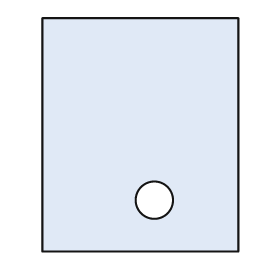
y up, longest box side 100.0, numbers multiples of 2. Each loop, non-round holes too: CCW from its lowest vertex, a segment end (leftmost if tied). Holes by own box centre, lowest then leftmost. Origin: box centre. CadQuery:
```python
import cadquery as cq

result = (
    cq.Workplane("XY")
    .moveTo(-42.0, -50.0)
    .lineTo(42.0, -50.0)
    .lineTo(42.0, 50.0)
    .lineTo(-42.0, 50.0)
    .close()
    .moveTo(6.0, -28.0)
    .circle(8.0)
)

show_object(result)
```